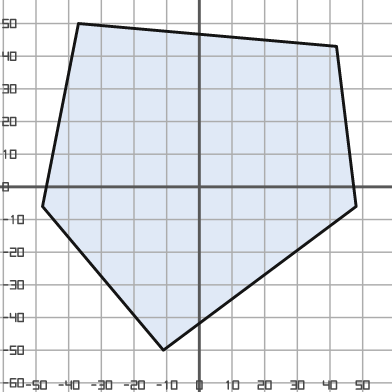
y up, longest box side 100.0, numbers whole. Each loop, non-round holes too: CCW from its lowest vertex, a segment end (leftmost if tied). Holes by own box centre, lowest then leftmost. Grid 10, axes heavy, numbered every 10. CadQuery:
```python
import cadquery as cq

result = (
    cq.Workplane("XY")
    .moveTo(-11.0, -50.0)
    .lineTo(48.0, -6.0)
    .lineTo(42.0, 43.0)
    .lineTo(-37.0, 50.0)
    .lineTo(-48.0, -6.0)
    .close()
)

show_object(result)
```